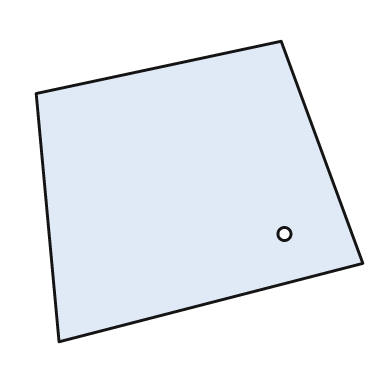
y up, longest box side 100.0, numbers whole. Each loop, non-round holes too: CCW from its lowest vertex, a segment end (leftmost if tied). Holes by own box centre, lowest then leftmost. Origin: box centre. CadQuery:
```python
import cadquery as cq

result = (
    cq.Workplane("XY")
    .moveTo(-43.0, -46.0)
    .lineTo(50.0, -22.0)
    .lineTo(25.0, 46.0)
    .lineTo(-50.0, 30.0)
    .close()
    .moveTo(26.0, -13.0)
    .circle(2.0)
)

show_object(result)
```